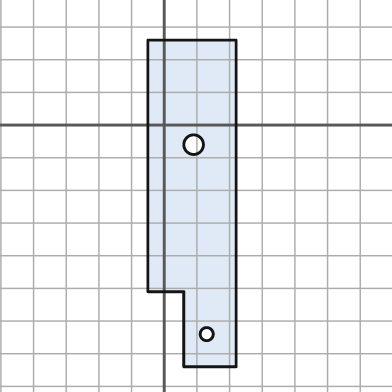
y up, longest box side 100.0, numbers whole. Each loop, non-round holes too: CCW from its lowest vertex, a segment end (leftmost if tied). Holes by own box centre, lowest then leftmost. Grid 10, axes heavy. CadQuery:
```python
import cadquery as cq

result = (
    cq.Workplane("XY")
    .moveTo(6.0, -74.0)
    .lineTo(22.0, -74.0)
    .lineTo(22.0, 26.0)
    .lineTo(-5.0, 26.0)
    .lineTo(-5.0, -51.0)
    .lineTo(6.0, -51.0)
    .close()
    .moveTo(13.0, -64.0)
    .circle(2.0)
    .moveTo(9.0, -6.0)
    .circle(3.0)
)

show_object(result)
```